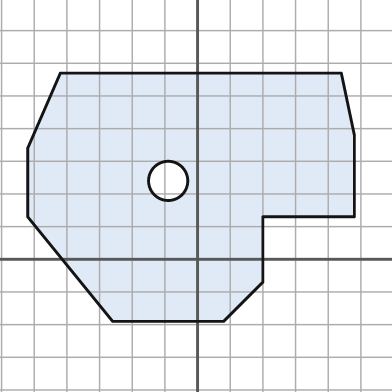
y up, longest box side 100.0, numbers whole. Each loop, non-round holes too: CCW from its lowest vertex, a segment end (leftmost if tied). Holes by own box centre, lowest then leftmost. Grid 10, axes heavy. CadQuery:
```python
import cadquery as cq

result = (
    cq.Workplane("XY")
    .moveTo(-26.0, -19.0)
    .lineTo(8.0, -19.0)
    .lineTo(20.0, -7.0)
    .lineTo(20.0, 13.0)
    .lineTo(48.0, 13.0)
    .lineTo(48.0, 38.0)
    .lineTo(44.0, 57.0)
    .lineTo(-42.0, 57.0)
    .lineTo(-52.0, 34.0)
    .lineTo(-52.0, 13.0)
    .close()
    .moveTo(-9.0, 24.0)
    .circle(6.0)
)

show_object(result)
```